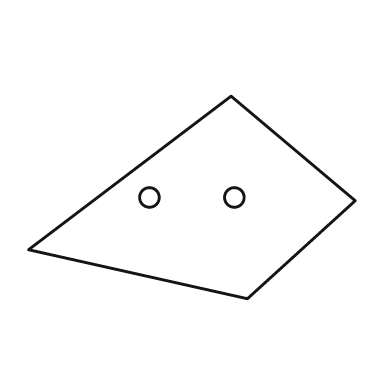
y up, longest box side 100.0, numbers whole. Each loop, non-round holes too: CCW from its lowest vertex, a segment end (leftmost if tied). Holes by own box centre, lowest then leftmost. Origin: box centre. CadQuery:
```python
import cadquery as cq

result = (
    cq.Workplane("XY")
    .moveTo(17.0, -31.0)
    .lineTo(50.0, -1.0)
    .lineTo(12.0, 31.0)
    .lineTo(-50.0, -16.0)
    .close()
    .moveTo(-13.0, 0.0)
    .circle(3.0)
    .moveTo(13.0, 0.0)
    .circle(3.0)
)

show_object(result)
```